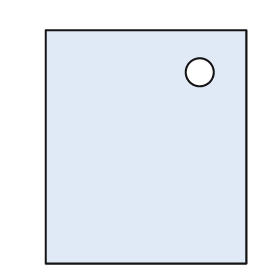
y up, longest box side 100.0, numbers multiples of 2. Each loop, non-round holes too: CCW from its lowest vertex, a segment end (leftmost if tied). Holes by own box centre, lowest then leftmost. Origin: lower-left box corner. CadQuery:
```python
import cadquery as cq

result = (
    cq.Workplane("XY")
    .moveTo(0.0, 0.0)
    .lineTo(86.0, 0.0)
    .lineTo(86.0, 100.0)
    .lineTo(0.0, 100.0)
    .close()
    .moveTo(66.0, 82.0)
    .circle(6.0)
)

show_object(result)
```